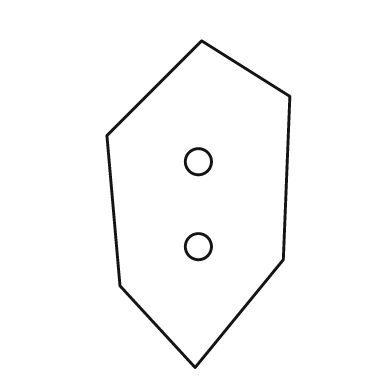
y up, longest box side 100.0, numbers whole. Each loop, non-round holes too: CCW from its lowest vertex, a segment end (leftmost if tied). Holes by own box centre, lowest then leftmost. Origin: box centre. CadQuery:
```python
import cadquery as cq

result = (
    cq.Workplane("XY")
    .moveTo(-1.0, -50.0)
    .lineTo(26.0, -17.0)
    .lineTo(28.0, 33.0)
    .lineTo(1.0, 50.0)
    .lineTo(-28.0, 21.0)
    .lineTo(-24.0, -25.0)
    .close()
    .moveTo(0.0, -13.0)
    .circle(4.0)
    .moveTo(0.0, 13.0)
    .circle(4.0)
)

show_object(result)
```